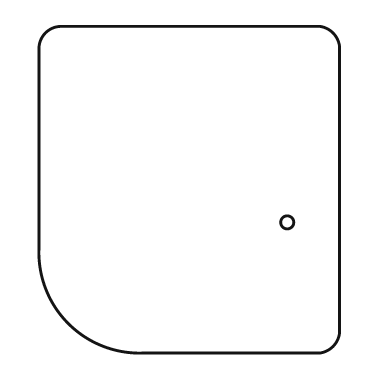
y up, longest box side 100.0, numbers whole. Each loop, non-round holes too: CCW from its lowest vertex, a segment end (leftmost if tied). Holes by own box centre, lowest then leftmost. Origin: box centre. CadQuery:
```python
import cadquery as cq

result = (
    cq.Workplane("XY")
    .moveTo(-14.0, -50.0)
    .lineTo(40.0, -50.0)
    .threePointArc((44.0, -48.0), (46.0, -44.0))
    .lineTo(46.0, 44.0)
    .threePointArc((44.0, 48.0), (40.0, 50.0))
    .lineTo(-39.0, 50.0)
    .threePointArc((-44.0, 48.0), (-46.0, 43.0))
    .lineTo(-46.0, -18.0)
    .threePointArc((-37.0, -41.0), (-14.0, -50.0))
    .close()
    .moveTo(30.0, -10.0)
    .circle(2.0)
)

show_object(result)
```